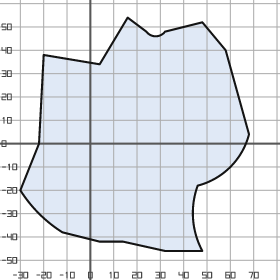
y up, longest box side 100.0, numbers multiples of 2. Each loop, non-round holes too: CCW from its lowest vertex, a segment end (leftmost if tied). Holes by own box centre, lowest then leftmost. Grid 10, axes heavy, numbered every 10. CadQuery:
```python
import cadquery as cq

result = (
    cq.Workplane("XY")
    .moveTo(32.0, -46.0)
    .lineTo(48.0, -46.0)
    .threePointArc((44.0, -32.0), (46.0, -18.0))
    .threePointArc((60.0, -10.0), (68.0, 4.0))
    .lineTo(58.0, 40.0)
    .lineTo(48.0, 52.0)
    .lineTo(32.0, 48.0)
    .threePointArc((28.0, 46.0), (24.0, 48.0))
    .lineTo(16.0, 54.0)
    .lineTo(4.0, 34.0)
    .lineTo(-20.0, 38.0)
    .lineTo(-22.0, 0.0)
    .lineTo(-30.0, -20.0)
    .threePointArc((-22.0, -30.0), (-12.0, -38.0))
    .lineTo(4.0, -42.0)
    .lineTo(14.0, -42.0)
    .close()
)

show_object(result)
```